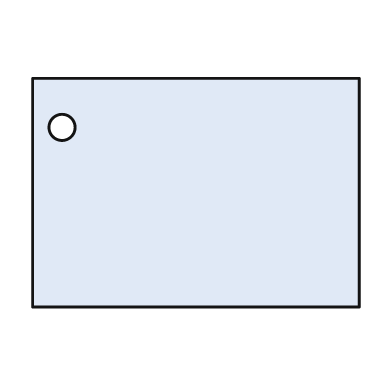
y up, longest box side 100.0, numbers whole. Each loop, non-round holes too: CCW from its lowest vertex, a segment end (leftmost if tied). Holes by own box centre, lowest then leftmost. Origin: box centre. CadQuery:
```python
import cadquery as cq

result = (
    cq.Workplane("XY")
    .moveTo(-50.0, -35.0)
    .lineTo(50.0, -35.0)
    .lineTo(50.0, 35.0)
    .lineTo(-50.0, 35.0)
    .close()
    .moveTo(-41.0, 20.0)
    .circle(4.0)
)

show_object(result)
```